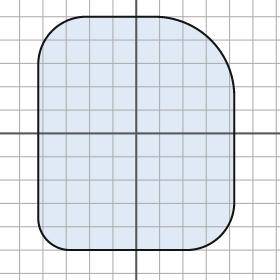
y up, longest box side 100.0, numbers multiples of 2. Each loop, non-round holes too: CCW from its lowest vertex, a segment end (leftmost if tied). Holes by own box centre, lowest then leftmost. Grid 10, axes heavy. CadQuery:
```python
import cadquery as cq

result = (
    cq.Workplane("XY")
    .moveTo(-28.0, -50.0)
    .lineTo(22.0, -50.0)
    .threePointArc((36.0, -44.0), (42.0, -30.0))
    .lineTo(42.0, 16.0)
    .threePointArc((32.0, 40.0), (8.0, 50.0))
    .lineTo(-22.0, 50.0)
    .threePointArc((-36.0, 44.0), (-42.0, 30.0))
    .lineTo(-42.0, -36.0)
    .threePointArc((-38.0, -46.0), (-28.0, -50.0))
    .close()
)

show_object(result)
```